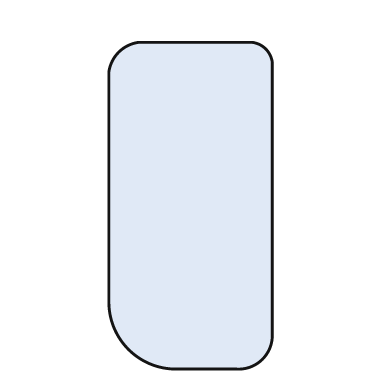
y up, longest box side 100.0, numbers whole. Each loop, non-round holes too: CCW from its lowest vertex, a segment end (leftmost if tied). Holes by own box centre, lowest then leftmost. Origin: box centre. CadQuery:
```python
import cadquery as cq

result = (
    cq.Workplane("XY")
    .moveTo(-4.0, -50.0)
    .lineTo(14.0, -50.0)
    .threePointArc((22.0, -47.0), (25.0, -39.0))
    .lineTo(25.0, 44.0)
    .threePointArc((23.0, 48.0), (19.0, 50.0))
    .lineTo(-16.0, 50.0)
    .threePointArc((-22.0, 47.0), (-25.0, 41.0))
    .lineTo(-25.0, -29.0)
    .threePointArc((-19.0, -44.0), (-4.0, -50.0))
    .close()
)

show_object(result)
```